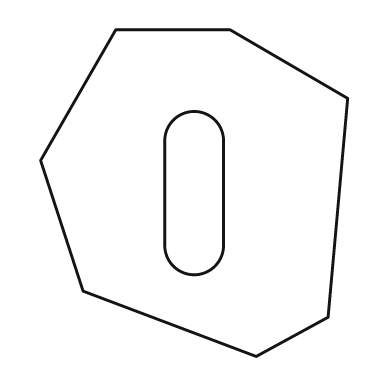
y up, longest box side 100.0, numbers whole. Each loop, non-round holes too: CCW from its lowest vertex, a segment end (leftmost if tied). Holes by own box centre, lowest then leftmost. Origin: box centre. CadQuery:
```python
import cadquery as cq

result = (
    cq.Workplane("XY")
    .moveTo(19.0, -50.0)
    .lineTo(41.0, -38.0)
    .lineTo(47.0, 29.0)
    .lineTo(11.0, 50.0)
    .lineTo(-24.0, 50.0)
    .lineTo(-47.0, 10.0)
    .lineTo(-34.0, -30.0)
    .close()
    .moveTo(-9.0, -16.0)
    .threePointArc((0.0, -25.0), (9.0, -16.0))
    .lineTo(9.0, 16.0)
    .threePointArc((0.0, 25.0), (-9.0, 16.0))
    .close()
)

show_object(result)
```